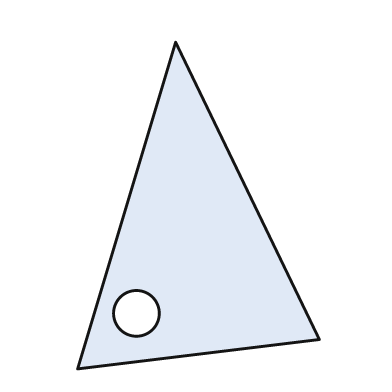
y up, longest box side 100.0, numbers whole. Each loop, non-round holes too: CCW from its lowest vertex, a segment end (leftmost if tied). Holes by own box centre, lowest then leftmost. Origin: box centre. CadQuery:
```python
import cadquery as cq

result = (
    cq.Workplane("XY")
    .moveTo(-37.0, -50.0)
    .lineTo(37.0, -41.0)
    .lineTo(-7.0, 50.0)
    .close()
    .moveTo(-19.0, -33.0)
    .circle(7.0)
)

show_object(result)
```